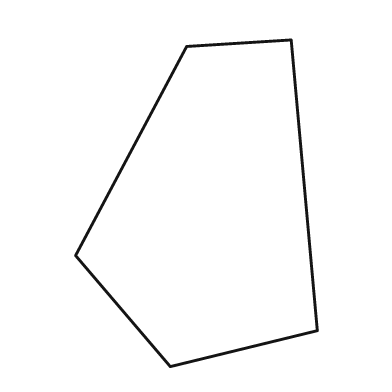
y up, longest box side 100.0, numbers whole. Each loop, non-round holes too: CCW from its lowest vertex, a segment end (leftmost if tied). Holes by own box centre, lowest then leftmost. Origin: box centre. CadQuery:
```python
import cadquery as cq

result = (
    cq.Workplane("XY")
    .moveTo(-8.0, -50.0)
    .lineTo(37.0, -39.0)
    .lineTo(29.0, 50.0)
    .lineTo(-3.0, 48.0)
    .lineTo(-37.0, -16.0)
    .close()
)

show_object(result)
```